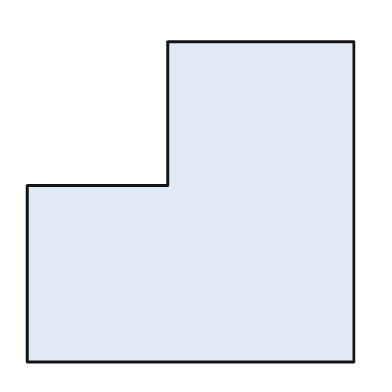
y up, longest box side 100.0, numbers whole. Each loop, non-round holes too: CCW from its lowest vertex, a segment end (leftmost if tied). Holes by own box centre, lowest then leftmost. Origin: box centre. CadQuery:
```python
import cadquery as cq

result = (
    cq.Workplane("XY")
    .moveTo(-50.0, -49.0)
    .lineTo(50.0, -49.0)
    .lineTo(50.0, 49.0)
    .lineTo(-7.0, 49.0)
    .lineTo(-7.0, 5.0)
    .lineTo(-50.0, 5.0)
    .close()
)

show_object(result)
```